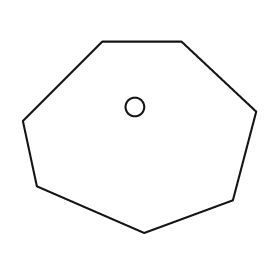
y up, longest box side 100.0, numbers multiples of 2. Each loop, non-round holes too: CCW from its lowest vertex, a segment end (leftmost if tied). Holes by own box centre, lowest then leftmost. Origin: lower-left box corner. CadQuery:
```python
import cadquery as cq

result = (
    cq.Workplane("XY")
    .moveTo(52.0, 0.0)
    .lineTo(90.0, 14.0)
    .lineTo(100.0, 52.0)
    .lineTo(68.0, 82.0)
    .lineTo(34.0, 82.0)
    .lineTo(0.0, 48.0)
    .lineTo(6.0, 20.0)
    .close()
    .moveTo(48.0, 54.0)
    .circle(4.0)
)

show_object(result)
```